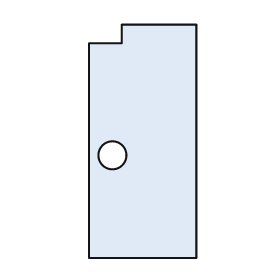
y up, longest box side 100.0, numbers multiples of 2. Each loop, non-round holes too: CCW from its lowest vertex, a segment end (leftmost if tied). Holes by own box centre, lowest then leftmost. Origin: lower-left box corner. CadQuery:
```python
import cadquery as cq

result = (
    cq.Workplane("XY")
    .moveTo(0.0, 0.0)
    .lineTo(46.0, 0.0)
    .lineTo(46.0, 100.0)
    .lineTo(14.0, 100.0)
    .lineTo(14.0, 92.0)
    .lineTo(0.0, 92.0)
    .close()
    .moveTo(10.0, 44.0)
    .circle(6.0)
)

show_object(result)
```